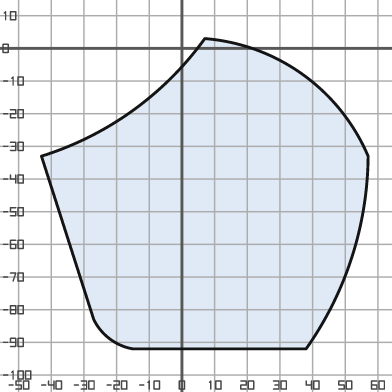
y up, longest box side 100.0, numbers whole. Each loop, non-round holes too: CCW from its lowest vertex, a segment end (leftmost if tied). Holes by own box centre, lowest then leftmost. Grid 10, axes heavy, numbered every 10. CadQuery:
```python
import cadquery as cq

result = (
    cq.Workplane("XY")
    .moveTo(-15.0, -92.0)
    .lineTo(38.0, -92.0)
    .threePointArc((52.0, -64.0), (57.0, -33.0))
    .threePointArc((37.0, -8.0), (7.0, 3.0))
    .threePointArc((-15.0, -19.0), (-43.0, -33.0))
    .lineTo(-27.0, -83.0)
    .threePointArc((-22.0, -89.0), (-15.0, -92.0))
    .close()
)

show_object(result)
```